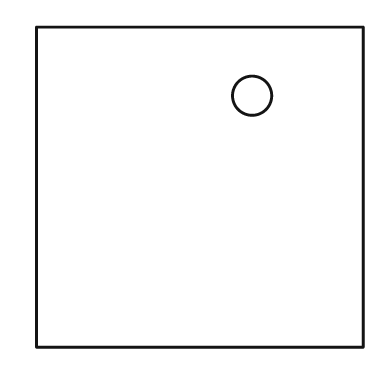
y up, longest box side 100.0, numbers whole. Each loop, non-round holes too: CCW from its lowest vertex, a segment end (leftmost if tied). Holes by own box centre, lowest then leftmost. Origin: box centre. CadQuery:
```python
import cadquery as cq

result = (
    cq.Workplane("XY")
    .moveTo(-50.0, -49.0)
    .lineTo(50.0, -49.0)
    .lineTo(50.0, 49.0)
    .lineTo(-50.0, 49.0)
    .close()
    .moveTo(16.0, 28.0)
    .circle(6.0)
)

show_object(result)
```